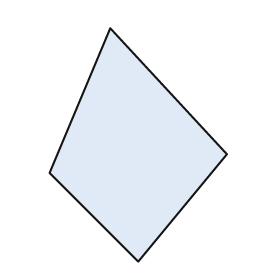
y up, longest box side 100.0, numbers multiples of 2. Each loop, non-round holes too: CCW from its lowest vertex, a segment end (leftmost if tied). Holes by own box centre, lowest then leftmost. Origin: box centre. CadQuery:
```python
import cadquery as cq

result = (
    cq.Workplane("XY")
    .moveTo(0.0, -50.0)
    .lineTo(38.0, -4.0)
    .lineTo(-12.0, 50.0)
    .lineTo(-38.0, -12.0)
    .close()
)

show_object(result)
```